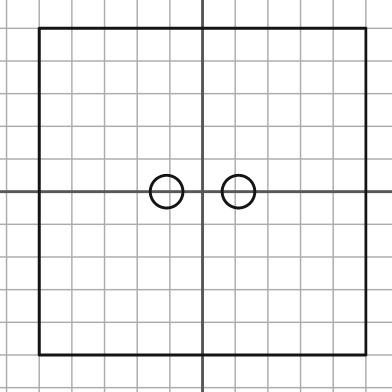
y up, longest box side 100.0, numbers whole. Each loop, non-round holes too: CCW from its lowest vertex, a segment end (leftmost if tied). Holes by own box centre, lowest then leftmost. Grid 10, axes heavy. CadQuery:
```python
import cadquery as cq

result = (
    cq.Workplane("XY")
    .moveTo(-50.0, -50.0)
    .lineTo(50.0, -50.0)
    .lineTo(50.0, 50.0)
    .lineTo(-50.0, 50.0)
    .close()
    .moveTo(-11.0, 0.0)
    .circle(5.0)
    .moveTo(11.0, 0.0)
    .circle(5.0)
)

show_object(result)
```